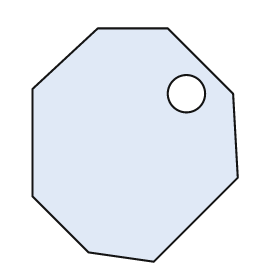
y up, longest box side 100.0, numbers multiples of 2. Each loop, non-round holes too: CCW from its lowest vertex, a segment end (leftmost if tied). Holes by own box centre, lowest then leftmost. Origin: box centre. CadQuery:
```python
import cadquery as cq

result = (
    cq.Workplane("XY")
    .moveTo(8.0, -50.0)
    .lineTo(44.0, -14.0)
    .lineTo(42.0, 22.0)
    .lineTo(14.0, 50.0)
    .lineTo(-16.0, 50.0)
    .lineTo(-44.0, 24.0)
    .lineTo(-44.0, -22.0)
    .lineTo(-20.0, -46.0)
    .close()
    .moveTo(22.0, 22.0)
    .circle(8.0)
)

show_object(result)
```